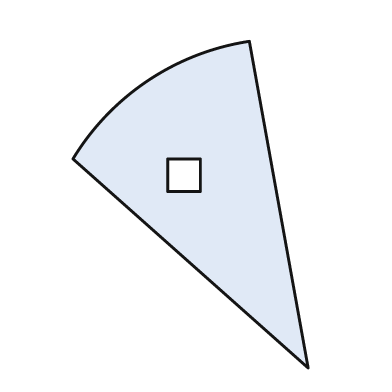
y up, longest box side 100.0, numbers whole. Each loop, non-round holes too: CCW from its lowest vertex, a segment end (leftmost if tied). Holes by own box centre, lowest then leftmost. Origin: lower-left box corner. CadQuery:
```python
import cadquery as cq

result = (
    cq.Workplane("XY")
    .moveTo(72.0, 0.0)
    .lineTo(54.0, 100.0)
    .threePointArc((23.0, 88.0), (0.0, 64.0))
    .close()
    .moveTo(29.0, 54.0)
    .lineTo(39.0, 54.0)
    .lineTo(39.0, 64.0)
    .lineTo(29.0, 64.0)
    .close()
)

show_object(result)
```